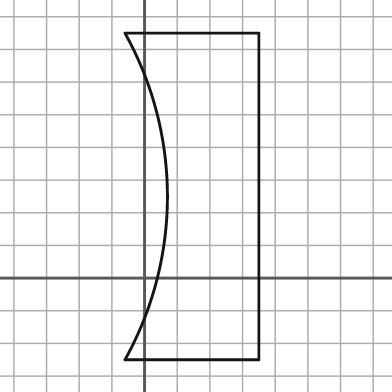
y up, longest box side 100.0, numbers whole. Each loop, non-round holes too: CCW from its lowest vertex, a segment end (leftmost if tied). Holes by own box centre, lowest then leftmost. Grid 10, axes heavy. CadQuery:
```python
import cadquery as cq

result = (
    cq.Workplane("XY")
    .moveTo(-6.0, -25.0)
    .lineTo(35.0, -25.0)
    .lineTo(35.0, 75.0)
    .lineTo(-6.0, 75.0)
    .threePointArc((7.0, 25.0), (-6.0, -25.0))
    .close()
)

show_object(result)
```